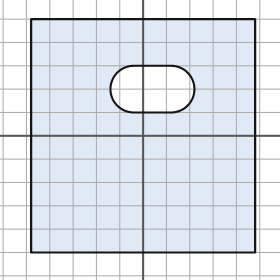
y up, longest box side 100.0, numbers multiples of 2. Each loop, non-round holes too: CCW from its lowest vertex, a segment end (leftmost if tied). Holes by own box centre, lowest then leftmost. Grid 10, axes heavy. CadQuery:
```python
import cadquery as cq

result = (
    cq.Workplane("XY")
    .moveTo(-48.0, -50.0)
    .lineTo(48.0, -50.0)
    .lineTo(48.0, 50.0)
    .lineTo(-48.0, 50.0)
    .close()
    .moveTo(-4.0, 10.0)
    .lineTo(12.0, 10.0)
    .threePointArc((22.0, 20.0), (12.0, 30.0))
    .lineTo(-4.0, 30.0)
    .threePointArc((-14.0, 20.0), (-4.0, 10.0))
    .close()
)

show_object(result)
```